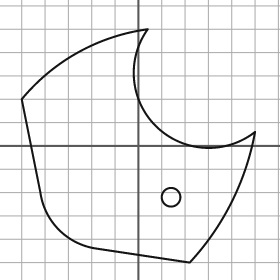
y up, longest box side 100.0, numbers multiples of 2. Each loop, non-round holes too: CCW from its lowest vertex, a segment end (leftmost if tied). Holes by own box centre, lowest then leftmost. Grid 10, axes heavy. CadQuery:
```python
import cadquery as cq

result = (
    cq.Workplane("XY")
    .moveTo(22.0, -50.0)
    .threePointArc((40.0, -24.0), (50.0, 6.0))
    .threePointArc((8.0, 8.0), (4.0, 50.0))
    .threePointArc((-26.0, 40.0), (-50.0, 20.0))
    .lineTo(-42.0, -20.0)
    .threePointArc((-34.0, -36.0), (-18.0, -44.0))
    .close()
    .moveTo(14.0, -22.0)
    .circle(4.0)
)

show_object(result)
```